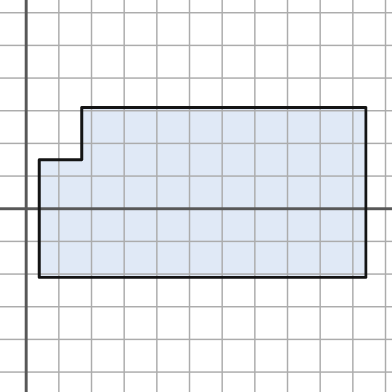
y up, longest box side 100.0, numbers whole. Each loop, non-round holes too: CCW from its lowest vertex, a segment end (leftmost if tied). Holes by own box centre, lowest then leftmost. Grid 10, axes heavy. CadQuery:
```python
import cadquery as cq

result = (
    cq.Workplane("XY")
    .moveTo(4.0, -21.0)
    .lineTo(104.0, -21.0)
    .lineTo(104.0, 31.0)
    .lineTo(17.0, 31.0)
    .lineTo(17.0, 15.0)
    .lineTo(4.0, 15.0)
    .close()
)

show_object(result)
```